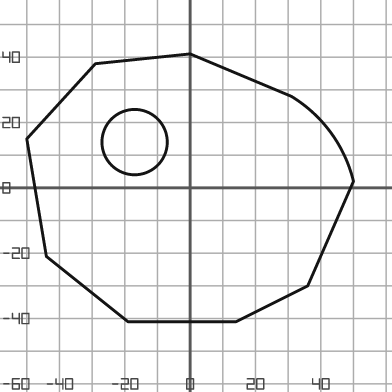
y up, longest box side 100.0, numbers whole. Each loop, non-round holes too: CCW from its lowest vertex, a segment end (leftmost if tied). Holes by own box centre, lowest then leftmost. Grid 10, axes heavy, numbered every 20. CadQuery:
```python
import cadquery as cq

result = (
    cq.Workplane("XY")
    .moveTo(-19.0, -41.0)
    .lineTo(14.0, -41.0)
    .lineTo(36.0, -30.0)
    .lineTo(50.0, 2.0)
    .threePointArc((43.0, 17.0), (31.0, 28.0))
    .lineTo(0.0, 41.0)
    .lineTo(-29.0, 38.0)
    .lineTo(-50.0, 15.0)
    .lineTo(-44.0, -21.0)
    .close()
    .moveTo(-17.0, 14.0)
    .circle(10.0)
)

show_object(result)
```